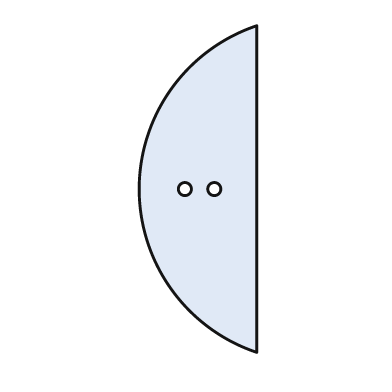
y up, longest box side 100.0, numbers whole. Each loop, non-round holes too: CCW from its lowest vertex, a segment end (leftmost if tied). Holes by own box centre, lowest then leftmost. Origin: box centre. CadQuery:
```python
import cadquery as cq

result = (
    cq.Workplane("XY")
    .moveTo(18.0, -50.0)
    .lineTo(18.0, 50.0)
    .threePointArc((-18.0, 0.0), (18.0, -50.0))
    .close()
    .moveTo(-4.0, 0.0)
    .circle(2.0)
    .moveTo(5.0, 0.0)
    .circle(2.0)
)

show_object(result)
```